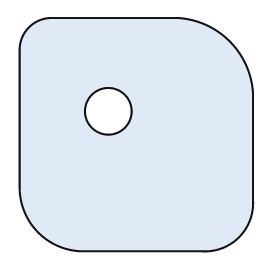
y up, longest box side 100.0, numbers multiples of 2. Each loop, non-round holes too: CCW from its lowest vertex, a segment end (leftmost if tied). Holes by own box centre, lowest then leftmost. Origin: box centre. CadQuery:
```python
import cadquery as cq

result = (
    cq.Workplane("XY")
    .moveTo(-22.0, -50.0)
    .lineTo(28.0, -50.0)
    .threePointArc((44.0, -44.0), (50.0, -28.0))
    .lineTo(50.0, 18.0)
    .threePointArc((40.0, 40.0), (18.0, 50.0))
    .lineTo(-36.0, 50.0)
    .threePointArc((-46.0, 46.0), (-50.0, 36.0))
    .lineTo(-50.0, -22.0)
    .threePointArc((-42.0, -42.0), (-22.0, -50.0))
    .close()
    .moveTo(-12.0, 10.0)
    .circle(10.0)
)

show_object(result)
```